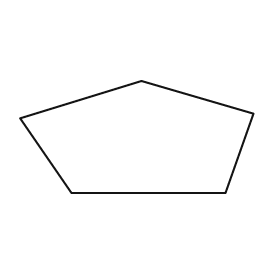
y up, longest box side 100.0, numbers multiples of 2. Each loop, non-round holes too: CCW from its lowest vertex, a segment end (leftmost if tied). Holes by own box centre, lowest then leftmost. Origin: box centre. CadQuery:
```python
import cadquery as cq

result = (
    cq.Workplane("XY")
    .moveTo(-28.0, -24.0)
    .lineTo(38.0, -24.0)
    .lineTo(50.0, 10.0)
    .lineTo(2.0, 24.0)
    .lineTo(-50.0, 8.0)
    .close()
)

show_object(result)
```